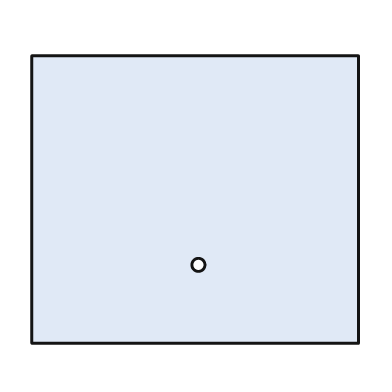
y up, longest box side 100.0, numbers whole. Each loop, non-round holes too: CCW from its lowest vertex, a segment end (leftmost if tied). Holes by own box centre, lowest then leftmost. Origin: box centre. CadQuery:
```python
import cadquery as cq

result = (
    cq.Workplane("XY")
    .moveTo(-50.0, -44.0)
    .lineTo(50.0, -44.0)
    .lineTo(50.0, 44.0)
    .lineTo(-50.0, 44.0)
    .close()
    .moveTo(1.0, -20.0)
    .circle(2.0)
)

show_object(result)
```